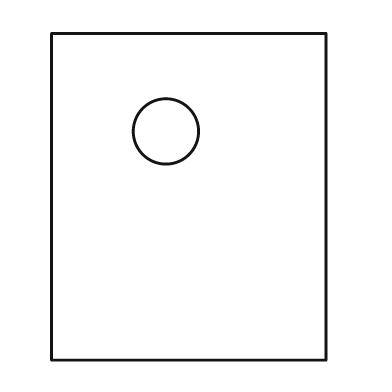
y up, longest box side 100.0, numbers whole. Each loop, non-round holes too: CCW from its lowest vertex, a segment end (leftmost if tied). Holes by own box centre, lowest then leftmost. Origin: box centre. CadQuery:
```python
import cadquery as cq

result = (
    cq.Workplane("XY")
    .moveTo(-42.0, -50.0)
    .lineTo(42.0, -50.0)
    .lineTo(42.0, 50.0)
    .lineTo(-42.0, 50.0)
    .close()
    .moveTo(-7.0, 20.0)
    .circle(10.0)
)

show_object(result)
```